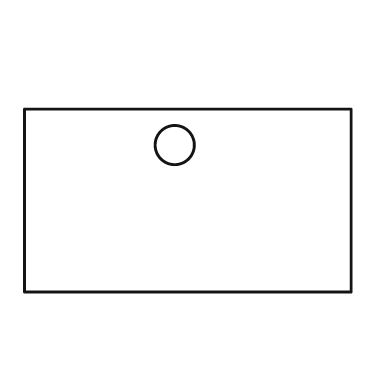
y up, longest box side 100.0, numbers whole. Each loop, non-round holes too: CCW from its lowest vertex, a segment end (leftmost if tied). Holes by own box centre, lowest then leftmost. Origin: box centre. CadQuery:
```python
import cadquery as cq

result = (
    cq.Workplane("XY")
    .moveTo(-50.0, -28.0)
    .lineTo(50.0, -28.0)
    .lineTo(50.0, 28.0)
    .lineTo(-50.0, 28.0)
    .close()
    .moveTo(-4.0, 17.0)
    .circle(6.0)
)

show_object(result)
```